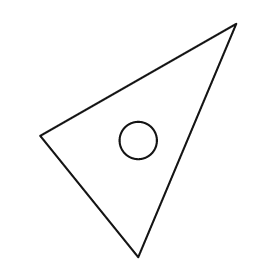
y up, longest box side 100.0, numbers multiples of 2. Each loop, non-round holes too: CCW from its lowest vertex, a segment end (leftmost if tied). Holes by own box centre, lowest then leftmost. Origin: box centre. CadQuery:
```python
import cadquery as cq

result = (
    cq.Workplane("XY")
    .moveTo(0.0, -50.0)
    .lineTo(42.0, 50.0)
    .lineTo(-42.0, 2.0)
    .close()
    .moveTo(0.0, 0.0)
    .circle(8.0)
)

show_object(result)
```